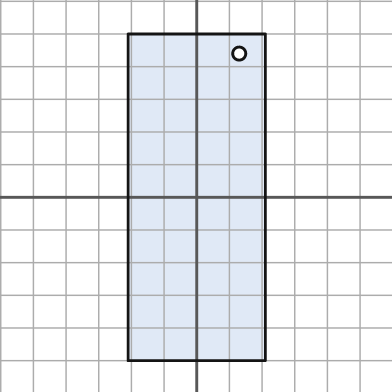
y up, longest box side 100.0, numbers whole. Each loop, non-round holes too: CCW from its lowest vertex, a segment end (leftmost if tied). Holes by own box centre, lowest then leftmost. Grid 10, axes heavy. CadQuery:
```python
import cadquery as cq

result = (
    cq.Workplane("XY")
    .moveTo(-21.0, -50.0)
    .lineTo(21.0, -50.0)
    .lineTo(21.0, 50.0)
    .lineTo(-21.0, 50.0)
    .close()
    .moveTo(13.0, 44.0)
    .circle(2.0)
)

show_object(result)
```